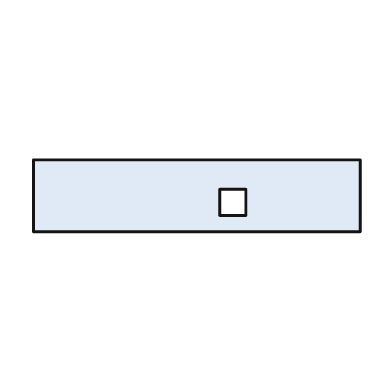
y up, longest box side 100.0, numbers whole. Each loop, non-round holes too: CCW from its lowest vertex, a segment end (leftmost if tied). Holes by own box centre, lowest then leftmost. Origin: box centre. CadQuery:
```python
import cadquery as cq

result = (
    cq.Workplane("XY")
    .moveTo(-50.0, -11.0)
    .lineTo(50.0, -11.0)
    .lineTo(50.0, 11.0)
    .lineTo(-50.0, 11.0)
    .close()
    .moveTo(7.0, -6.0)
    .lineTo(15.0, -6.0)
    .lineTo(15.0, 2.0)
    .lineTo(7.0, 2.0)
    .close()
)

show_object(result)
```